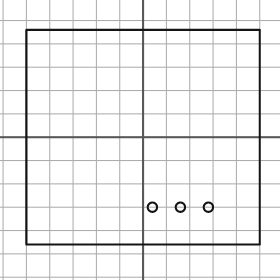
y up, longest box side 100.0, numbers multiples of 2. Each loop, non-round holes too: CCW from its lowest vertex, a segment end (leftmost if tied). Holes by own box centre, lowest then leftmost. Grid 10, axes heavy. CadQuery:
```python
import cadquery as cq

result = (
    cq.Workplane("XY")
    .moveTo(-50.0, -46.0)
    .lineTo(50.0, -46.0)
    .lineTo(50.0, 46.0)
    .lineTo(-50.0, 46.0)
    .close()
    .moveTo(4.0, -30.0)
    .circle(2.0)
    .moveTo(16.0, -30.0)
    .circle(2.0)
    .moveTo(28.0, -30.0)
    .circle(2.0)
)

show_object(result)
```